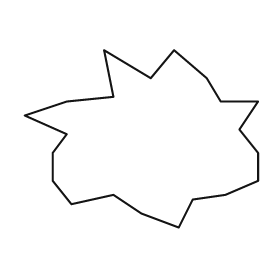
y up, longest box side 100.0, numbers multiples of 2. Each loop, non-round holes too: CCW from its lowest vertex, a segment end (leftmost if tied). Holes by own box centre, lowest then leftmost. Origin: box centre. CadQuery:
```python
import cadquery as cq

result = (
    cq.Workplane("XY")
    .moveTo(16.0, -38.0)
    .lineTo(22.0, -26.0)
    .lineTo(36.0, -24.0)
    .lineTo(50.0, -18.0)
    .lineTo(50.0, -6.0)
    .lineTo(42.0, 4.0)
    .lineTo(50.0, 16.0)
    .lineTo(34.0, 16.0)
    .lineTo(28.0, 26.0)
    .lineTo(14.0, 38.0)
    .lineTo(4.0, 26.0)
    .lineTo(-16.0, 38.0)
    .lineTo(-12.0, 18.0)
    .lineTo(-32.0, 16.0)
    .lineTo(-50.0, 10.0)
    .lineTo(-32.0, 2.0)
    .lineTo(-38.0, -6.0)
    .lineTo(-38.0, -18.0)
    .lineTo(-30.0, -28.0)
    .lineTo(-12.0, -24.0)
    .lineTo(0.0, -32.0)
    .close()
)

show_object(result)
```